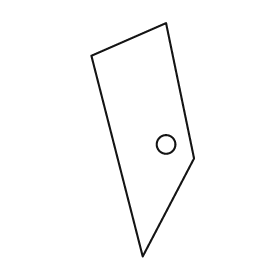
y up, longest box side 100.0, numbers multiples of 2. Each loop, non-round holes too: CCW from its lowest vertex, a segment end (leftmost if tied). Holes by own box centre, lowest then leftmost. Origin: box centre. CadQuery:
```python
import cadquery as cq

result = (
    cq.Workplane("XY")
    .moveTo(0.0, -50.0)
    .lineTo(22.0, -8.0)
    .lineTo(10.0, 50.0)
    .lineTo(-22.0, 36.0)
    .close()
    .moveTo(10.0, -2.0)
    .circle(4.0)
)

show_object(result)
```